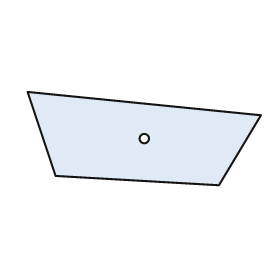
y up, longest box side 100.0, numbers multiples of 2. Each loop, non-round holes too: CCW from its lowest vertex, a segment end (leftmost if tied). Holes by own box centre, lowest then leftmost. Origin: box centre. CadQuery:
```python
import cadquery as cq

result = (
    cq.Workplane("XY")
    .moveTo(32.0, -20.0)
    .lineTo(50.0, 10.0)
    .lineTo(-50.0, 20.0)
    .lineTo(-38.0, -16.0)
    .close()
    .moveTo(0.0, 0.0)
    .circle(2.0)
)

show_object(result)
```